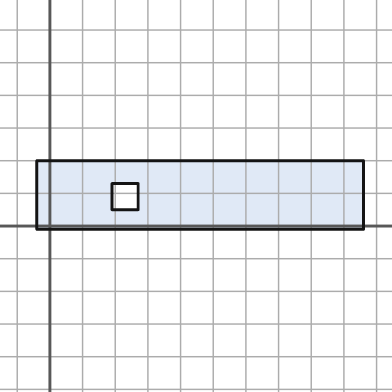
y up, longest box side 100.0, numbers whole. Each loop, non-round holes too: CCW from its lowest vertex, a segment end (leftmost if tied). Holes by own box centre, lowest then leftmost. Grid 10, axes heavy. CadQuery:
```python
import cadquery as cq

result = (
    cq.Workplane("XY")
    .moveTo(-4.0, -1.0)
    .lineTo(96.0, -1.0)
    .lineTo(96.0, 20.0)
    .lineTo(-4.0, 20.0)
    .close()
    .moveTo(19.0, 5.0)
    .lineTo(27.0, 5.0)
    .lineTo(27.0, 13.0)
    .lineTo(19.0, 13.0)
    .close()
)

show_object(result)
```